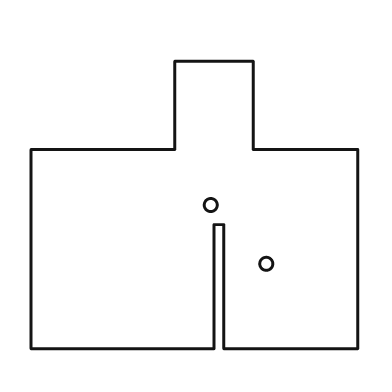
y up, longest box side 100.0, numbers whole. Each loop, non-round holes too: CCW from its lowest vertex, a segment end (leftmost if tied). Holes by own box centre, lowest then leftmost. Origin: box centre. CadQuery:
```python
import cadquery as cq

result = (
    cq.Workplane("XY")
    .moveTo(-50.0, -44.0)
    .lineTo(6.0, -44.0)
    .lineTo(6.0, -6.0)
    .lineTo(9.0, -6.0)
    .lineTo(9.0, -44.0)
    .lineTo(50.0, -44.0)
    .lineTo(50.0, 17.0)
    .lineTo(18.0, 17.0)
    .lineTo(18.0, 44.0)
    .lineTo(-6.0, 44.0)
    .lineTo(-6.0, 17.0)
    .lineTo(-50.0, 17.0)
    .close()
    .moveTo(22.0, -18.0)
    .circle(2.0)
    .moveTo(5.0, 0.0)
    .circle(2.0)
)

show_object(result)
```